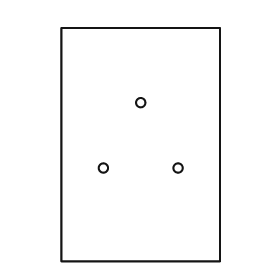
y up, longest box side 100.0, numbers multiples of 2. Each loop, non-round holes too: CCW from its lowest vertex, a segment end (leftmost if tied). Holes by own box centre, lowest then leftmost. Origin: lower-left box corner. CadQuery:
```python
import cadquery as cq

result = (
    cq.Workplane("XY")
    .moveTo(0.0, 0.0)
    .lineTo(68.0, 0.0)
    .lineTo(68.0, 100.0)
    .lineTo(0.0, 100.0)
    .close()
    .moveTo(18.0, 40.0)
    .circle(2.0)
    .moveTo(50.0, 40.0)
    .circle(2.0)
    .moveTo(34.0, 68.0)
    .circle(2.0)
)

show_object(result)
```